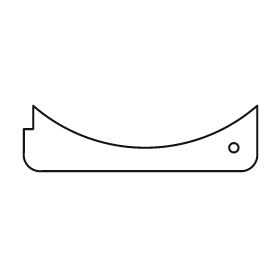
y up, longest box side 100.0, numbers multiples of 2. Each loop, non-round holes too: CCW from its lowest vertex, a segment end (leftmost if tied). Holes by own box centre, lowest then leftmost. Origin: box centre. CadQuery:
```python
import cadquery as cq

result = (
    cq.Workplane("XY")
    .moveTo(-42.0, -14.0)
    .lineTo(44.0, -14.0)
    .threePointArc((48.0, -12.0), (50.0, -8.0))
    .lineTo(50.0, 14.0)
    .threePointArc((2.0, -4.0), (-46.0, 14.0))
    .lineTo(-46.0, 4.0)
    .lineTo(-50.0, 4.0)
    .lineTo(-50.0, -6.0)
    .threePointArc((-48.0, -12.0), (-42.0, -14.0))
    .close()
    .moveTo(40.0, -4.0)
    .circle(2.0)
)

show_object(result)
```